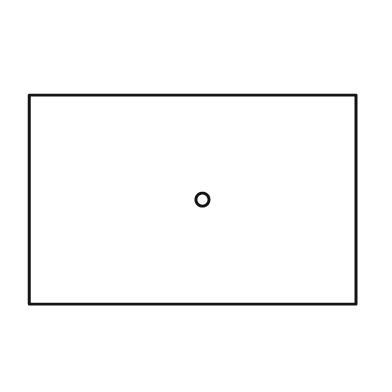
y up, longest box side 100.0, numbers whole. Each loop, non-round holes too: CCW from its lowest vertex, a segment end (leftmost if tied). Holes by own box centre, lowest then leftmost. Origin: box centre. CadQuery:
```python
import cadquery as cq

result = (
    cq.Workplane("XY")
    .moveTo(-50.0, -32.0)
    .lineTo(50.0, -32.0)
    .lineTo(50.0, 32.0)
    .lineTo(-50.0, 32.0)
    .close()
    .moveTo(3.0, 0.0)
    .circle(2.0)
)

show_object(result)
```